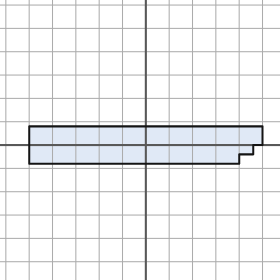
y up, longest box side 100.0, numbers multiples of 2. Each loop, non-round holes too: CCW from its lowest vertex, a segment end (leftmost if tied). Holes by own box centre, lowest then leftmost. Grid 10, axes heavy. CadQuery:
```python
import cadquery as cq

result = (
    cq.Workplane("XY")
    .moveTo(-50.0, -8.0)
    .lineTo(40.0, -8.0)
    .lineTo(40.0, -4.0)
    .lineTo(46.0, -4.0)
    .lineTo(46.0, 0.0)
    .lineTo(50.0, 0.0)
    .lineTo(50.0, 8.0)
    .lineTo(-50.0, 8.0)
    .close()
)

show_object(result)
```